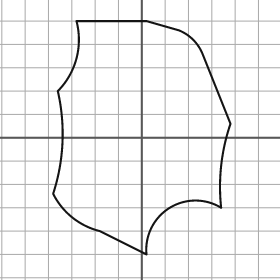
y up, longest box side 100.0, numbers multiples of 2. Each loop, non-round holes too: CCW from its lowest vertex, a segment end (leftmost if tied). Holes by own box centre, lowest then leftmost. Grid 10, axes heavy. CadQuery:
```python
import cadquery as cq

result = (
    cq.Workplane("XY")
    .moveTo(2.0, -50.0)
    .threePointArc((12.0, -30.0), (34.0, -30.0))
    .threePointArc((34.0, -12.0), (38.0, 6.0))
    .lineTo(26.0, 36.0)
    .threePointArc((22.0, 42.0), (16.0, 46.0))
    .lineTo(2.0, 50.0)
    .lineTo(-28.0, 50.0)
    .threePointArc((-28.0, 34.0), (-36.0, 20.0))
    .threePointArc((-34.0, -2.0), (-38.0, -24.0))
    .threePointArc((-30.0, -34.0), (-18.0, -40.0))
    .close()
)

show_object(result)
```